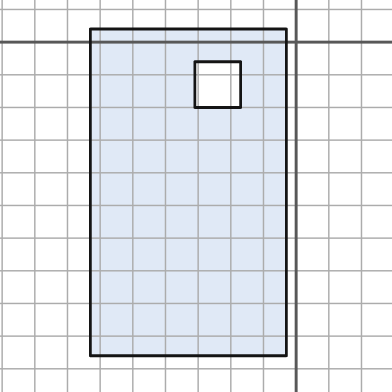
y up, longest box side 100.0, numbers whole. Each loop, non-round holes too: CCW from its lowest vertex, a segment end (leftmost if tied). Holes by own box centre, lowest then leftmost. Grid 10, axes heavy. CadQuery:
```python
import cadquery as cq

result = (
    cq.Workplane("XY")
    .moveTo(-63.0, -96.0)
    .lineTo(-3.0, -96.0)
    .lineTo(-3.0, 4.0)
    .lineTo(-63.0, 4.0)
    .close()
    .moveTo(-31.0, -20.0)
    .lineTo(-17.0, -20.0)
    .lineTo(-17.0, -6.0)
    .lineTo(-31.0, -6.0)
    .close()
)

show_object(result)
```